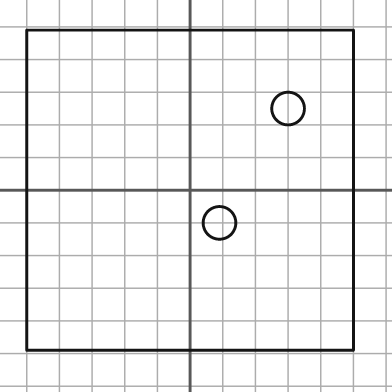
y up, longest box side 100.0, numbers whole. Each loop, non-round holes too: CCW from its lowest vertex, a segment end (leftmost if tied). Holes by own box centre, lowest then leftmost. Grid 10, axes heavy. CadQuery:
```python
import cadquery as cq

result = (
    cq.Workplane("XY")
    .moveTo(-50.0, -49.0)
    .lineTo(50.0, -49.0)
    .lineTo(50.0, 49.0)
    .lineTo(-50.0, 49.0)
    .close()
    .moveTo(9.0, -10.0)
    .circle(5.0)
    .moveTo(30.0, 25.0)
    .circle(5.0)
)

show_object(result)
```